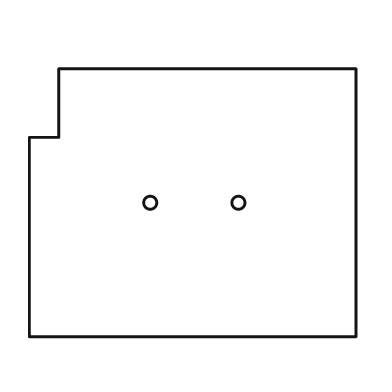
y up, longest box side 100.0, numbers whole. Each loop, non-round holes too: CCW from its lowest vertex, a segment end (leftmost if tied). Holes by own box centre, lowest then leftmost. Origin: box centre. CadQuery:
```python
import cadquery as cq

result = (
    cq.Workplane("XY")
    .moveTo(-50.0, -41.0)
    .lineTo(50.0, -41.0)
    .lineTo(50.0, 41.0)
    .lineTo(-41.0, 41.0)
    .lineTo(-41.0, 20.0)
    .lineTo(-50.0, 20.0)
    .close()
    .moveTo(-13.0, 0.0)
    .circle(2.0)
    .moveTo(14.0, 0.0)
    .circle(2.0)
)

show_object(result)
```